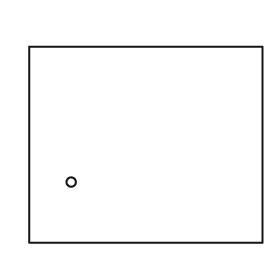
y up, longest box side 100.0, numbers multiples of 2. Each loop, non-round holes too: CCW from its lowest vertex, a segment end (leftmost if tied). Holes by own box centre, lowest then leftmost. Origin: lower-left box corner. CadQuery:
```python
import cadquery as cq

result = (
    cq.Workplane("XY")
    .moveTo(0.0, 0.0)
    .lineTo(100.0, 0.0)
    .lineTo(100.0, 84.0)
    .lineTo(0.0, 84.0)
    .close()
    .moveTo(18.0, 26.0)
    .circle(2.0)
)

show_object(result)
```